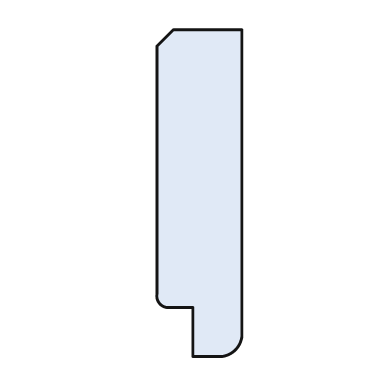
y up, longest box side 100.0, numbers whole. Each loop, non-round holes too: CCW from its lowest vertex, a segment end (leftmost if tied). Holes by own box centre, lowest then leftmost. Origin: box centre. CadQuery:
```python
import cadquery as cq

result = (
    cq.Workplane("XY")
    .moveTo(-2.0, -50.0)
    .lineTo(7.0, -50.0)
    .threePointArc((11.0, -48.0), (13.0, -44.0))
    .lineTo(13.0, 50.0)
    .lineTo(-8.0, 50.0)
    .lineTo(-13.0, 45.0)
    .lineTo(-13.0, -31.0)
    .threePointArc((-12.0, -34.0), (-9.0, -35.0))
    .lineTo(-2.0, -35.0)
    .close()
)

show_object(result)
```